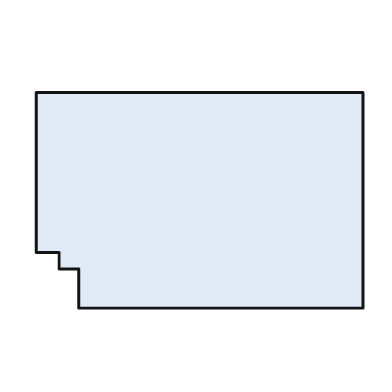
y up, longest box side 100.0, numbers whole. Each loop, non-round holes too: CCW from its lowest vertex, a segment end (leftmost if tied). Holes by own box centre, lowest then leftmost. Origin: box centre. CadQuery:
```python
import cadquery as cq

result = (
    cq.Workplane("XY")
    .moveTo(-37.0, -33.0)
    .lineTo(50.0, -33.0)
    .lineTo(50.0, 33.0)
    .lineTo(-50.0, 33.0)
    .lineTo(-50.0, -16.0)
    .lineTo(-43.0, -16.0)
    .lineTo(-43.0, -21.0)
    .lineTo(-37.0, -21.0)
    .close()
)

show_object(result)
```